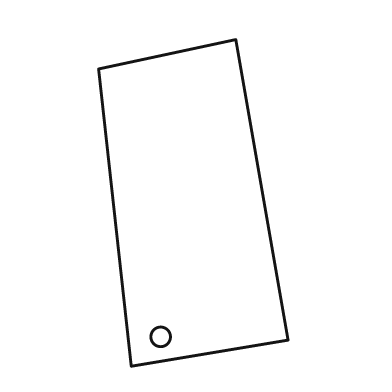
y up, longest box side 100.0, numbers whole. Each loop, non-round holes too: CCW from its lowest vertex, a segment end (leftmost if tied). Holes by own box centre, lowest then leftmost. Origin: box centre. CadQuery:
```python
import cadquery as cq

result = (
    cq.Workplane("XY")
    .moveTo(-19.0, -50.0)
    .lineTo(29.0, -42.0)
    .lineTo(13.0, 50.0)
    .lineTo(-29.0, 41.0)
    .close()
    .moveTo(-10.0, -41.0)
    .circle(3.0)
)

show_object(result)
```